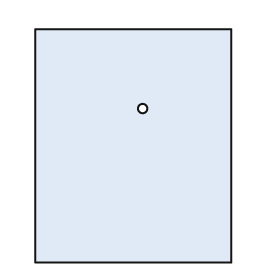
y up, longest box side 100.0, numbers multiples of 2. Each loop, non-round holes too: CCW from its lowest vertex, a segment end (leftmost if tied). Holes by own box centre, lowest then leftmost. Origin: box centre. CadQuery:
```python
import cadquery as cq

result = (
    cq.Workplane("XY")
    .moveTo(-42.0, -50.0)
    .lineTo(42.0, -50.0)
    .lineTo(42.0, 50.0)
    .lineTo(-42.0, 50.0)
    .close()
    .moveTo(4.0, 16.0)
    .circle(2.0)
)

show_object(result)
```